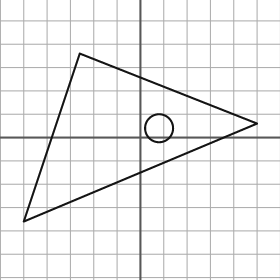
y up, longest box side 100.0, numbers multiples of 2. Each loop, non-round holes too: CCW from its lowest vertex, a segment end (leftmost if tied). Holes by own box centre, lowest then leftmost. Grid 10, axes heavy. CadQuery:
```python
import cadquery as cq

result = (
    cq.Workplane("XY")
    .moveTo(-50.0, -36.0)
    .lineTo(50.0, 6.0)
    .lineTo(-26.0, 36.0)
    .close()
    .moveTo(8.0, 4.0)
    .circle(6.0)
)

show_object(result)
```